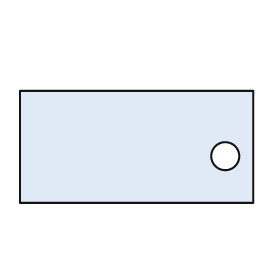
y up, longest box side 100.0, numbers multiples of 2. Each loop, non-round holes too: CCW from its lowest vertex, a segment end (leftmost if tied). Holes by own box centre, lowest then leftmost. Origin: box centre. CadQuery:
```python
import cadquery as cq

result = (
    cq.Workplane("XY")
    .moveTo(-50.0, -24.0)
    .lineTo(50.0, -24.0)
    .lineTo(50.0, 24.0)
    .lineTo(-50.0, 24.0)
    .close()
    .moveTo(38.0, -4.0)
    .circle(6.0)
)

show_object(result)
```